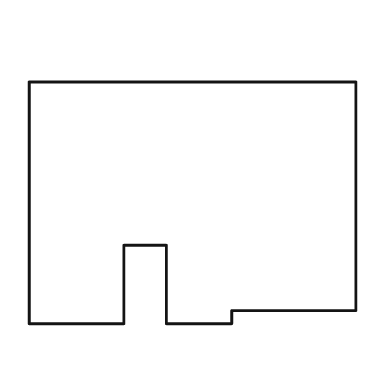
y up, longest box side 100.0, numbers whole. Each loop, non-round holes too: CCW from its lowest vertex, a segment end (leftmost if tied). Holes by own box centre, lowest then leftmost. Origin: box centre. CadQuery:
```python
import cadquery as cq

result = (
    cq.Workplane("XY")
    .moveTo(-50.0, -37.0)
    .lineTo(-21.0, -37.0)
    .lineTo(-21.0, -13.0)
    .lineTo(-8.0, -13.0)
    .lineTo(-8.0, -37.0)
    .lineTo(12.0, -37.0)
    .lineTo(12.0, -33.0)
    .lineTo(50.0, -33.0)
    .lineTo(50.0, 37.0)
    .lineTo(-50.0, 37.0)
    .close()
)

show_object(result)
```